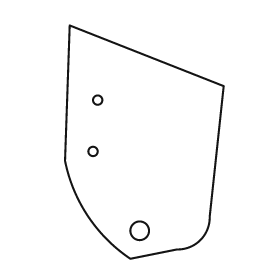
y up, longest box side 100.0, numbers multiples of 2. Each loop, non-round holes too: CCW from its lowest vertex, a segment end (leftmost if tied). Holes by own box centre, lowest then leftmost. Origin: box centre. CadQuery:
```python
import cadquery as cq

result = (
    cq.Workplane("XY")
    .moveTo(-6.0, -50.0)
    .lineTo(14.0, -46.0)
    .threePointArc((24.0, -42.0), (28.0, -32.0))
    .lineTo(34.0, 24.0)
    .lineTo(-32.0, 50.0)
    .lineTo(-34.0, -8.0)
    .threePointArc((-24.0, -32.0), (-6.0, -50.0))
    .close()
    .moveTo(-2.0, -38.0)
    .circle(4.0)
    .moveTo(-22.0, -4.0)
    .circle(2.0)
    .moveTo(-20.0, 18.0)
    .circle(2.0)
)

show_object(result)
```